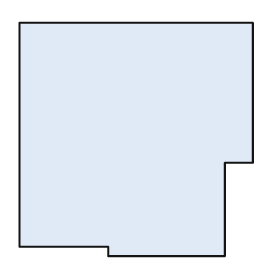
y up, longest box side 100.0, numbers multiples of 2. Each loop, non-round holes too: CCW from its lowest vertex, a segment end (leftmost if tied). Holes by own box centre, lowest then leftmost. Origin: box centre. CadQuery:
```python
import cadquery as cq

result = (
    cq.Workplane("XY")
    .moveTo(-12.0, -50.0)
    .lineTo(38.0, -50.0)
    .lineTo(38.0, -10.0)
    .lineTo(50.0, -10.0)
    .lineTo(50.0, 50.0)
    .lineTo(-50.0, 50.0)
    .lineTo(-50.0, -46.0)
    .lineTo(-12.0, -46.0)
    .close()
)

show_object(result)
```